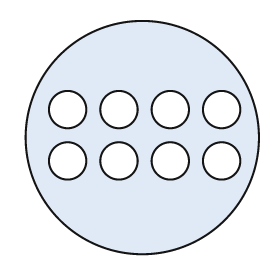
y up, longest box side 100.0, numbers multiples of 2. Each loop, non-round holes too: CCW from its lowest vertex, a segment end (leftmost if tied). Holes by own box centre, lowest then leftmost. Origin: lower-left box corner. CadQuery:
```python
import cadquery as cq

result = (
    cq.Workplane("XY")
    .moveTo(50.0, 50.0)
    .circle(50.0)
    .moveTo(18.0, 40.0)
    .circle(8.0)
    .moveTo(40.0, 40.0)
    .circle(8.0)
    .moveTo(62.0, 40.0)
    .circle(8.0)
    .moveTo(84.0, 40.0)
    .circle(8.0)
    .moveTo(18.0, 62.0)
    .circle(8.0)
    .moveTo(40.0, 62.0)
    .circle(8.0)
    .moveTo(62.0, 62.0)
    .circle(8.0)
    .moveTo(84.0, 62.0)
    .circle(8.0)
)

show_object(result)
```